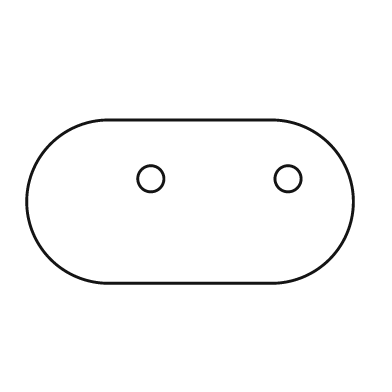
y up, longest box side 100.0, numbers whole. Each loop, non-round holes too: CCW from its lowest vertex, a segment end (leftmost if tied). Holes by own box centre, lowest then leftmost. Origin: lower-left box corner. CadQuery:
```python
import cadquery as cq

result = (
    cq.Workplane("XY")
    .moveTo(25.0, 0.0)
    .lineTo(75.0, 0.0)
    .threePointArc((100.0, 25.0), (75.0, 50.0))
    .lineTo(25.0, 50.0)
    .threePointArc((0.0, 25.0), (25.0, 0.0))
    .close()
    .moveTo(38.0, 32.0)
    .circle(4.0)
    .moveTo(80.0, 32.0)
    .circle(4.0)
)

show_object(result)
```